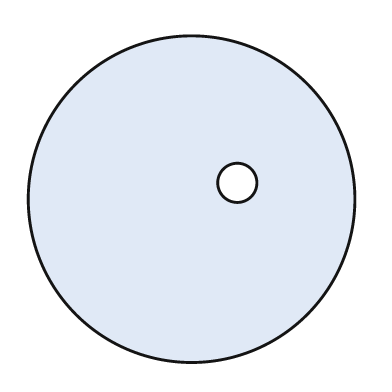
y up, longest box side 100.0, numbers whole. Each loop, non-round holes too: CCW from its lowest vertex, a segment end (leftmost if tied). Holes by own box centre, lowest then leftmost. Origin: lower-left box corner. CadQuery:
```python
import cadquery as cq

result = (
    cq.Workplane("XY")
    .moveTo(50.0, 50.0)
    .circle(50.0)
    .moveTo(64.0, 55.0)
    .circle(6.0)
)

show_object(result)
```